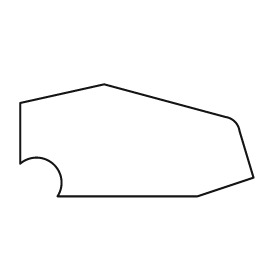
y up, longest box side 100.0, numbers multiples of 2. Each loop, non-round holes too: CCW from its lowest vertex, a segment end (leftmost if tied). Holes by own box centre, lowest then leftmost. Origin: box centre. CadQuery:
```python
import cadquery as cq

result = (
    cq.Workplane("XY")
    .moveTo(-34.0, -24.0)
    .lineTo(26.0, -24.0)
    .lineTo(50.0, -16.0)
    .lineTo(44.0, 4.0)
    .threePointArc((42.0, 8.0), (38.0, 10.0))
    .lineTo(-14.0, 24.0)
    .lineTo(-50.0, 16.0)
    .lineTo(-50.0, -10.0)
    .threePointArc((-36.0, -10.0), (-34.0, -24.0))
    .close()
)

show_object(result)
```